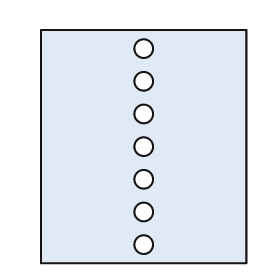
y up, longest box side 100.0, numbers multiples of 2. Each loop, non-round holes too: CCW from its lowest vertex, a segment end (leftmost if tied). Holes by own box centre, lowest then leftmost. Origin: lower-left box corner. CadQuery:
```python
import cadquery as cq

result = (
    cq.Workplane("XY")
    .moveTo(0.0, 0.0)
    .lineTo(88.0, 0.0)
    .lineTo(88.0, 100.0)
    .lineTo(0.0, 100.0)
    .close()
    .moveTo(44.0, 8.0)
    .circle(4.0)
    .moveTo(44.0, 22.0)
    .circle(4.0)
    .moveTo(44.0, 36.0)
    .circle(4.0)
    .moveTo(44.0, 50.0)
    .circle(4.0)
    .moveTo(44.0, 64.0)
    .circle(4.0)
    .moveTo(44.0, 78.0)
    .circle(4.0)
    .moveTo(44.0, 92.0)
    .circle(4.0)
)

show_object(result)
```